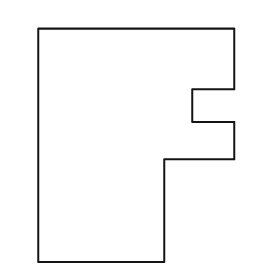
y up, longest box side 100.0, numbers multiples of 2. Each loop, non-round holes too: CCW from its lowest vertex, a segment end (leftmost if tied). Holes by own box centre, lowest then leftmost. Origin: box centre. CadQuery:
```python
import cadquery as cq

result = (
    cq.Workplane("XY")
    .moveTo(-42.0, -50.0)
    .lineTo(12.0, -50.0)
    .lineTo(12.0, -6.0)
    .lineTo(42.0, -6.0)
    .lineTo(42.0, 10.0)
    .lineTo(24.0, 10.0)
    .lineTo(24.0, 24.0)
    .lineTo(42.0, 24.0)
    .lineTo(42.0, 50.0)
    .lineTo(-42.0, 50.0)
    .close()
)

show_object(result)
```